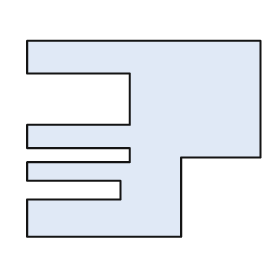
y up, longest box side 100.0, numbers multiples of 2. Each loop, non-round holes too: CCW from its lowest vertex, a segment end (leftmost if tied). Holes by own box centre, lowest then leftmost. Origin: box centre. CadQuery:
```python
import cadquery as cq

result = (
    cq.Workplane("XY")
    .moveTo(-50.0, -42.0)
    .lineTo(16.0, -42.0)
    .lineTo(16.0, -8.0)
    .lineTo(50.0, -8.0)
    .lineTo(50.0, 42.0)
    .lineTo(-50.0, 42.0)
    .lineTo(-50.0, 28.0)
    .lineTo(-6.0, 28.0)
    .lineTo(-6.0, 6.0)
    .lineTo(-50.0, 6.0)
    .lineTo(-50.0, -4.0)
    .lineTo(-6.0, -4.0)
    .lineTo(-6.0, -10.0)
    .lineTo(-50.0, -10.0)
    .lineTo(-50.0, -18.0)
    .lineTo(-10.0, -18.0)
    .lineTo(-10.0, -26.0)
    .lineTo(-50.0, -26.0)
    .close()
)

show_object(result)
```